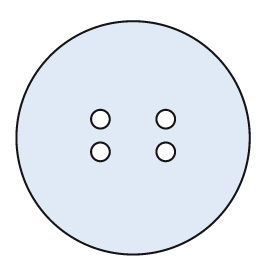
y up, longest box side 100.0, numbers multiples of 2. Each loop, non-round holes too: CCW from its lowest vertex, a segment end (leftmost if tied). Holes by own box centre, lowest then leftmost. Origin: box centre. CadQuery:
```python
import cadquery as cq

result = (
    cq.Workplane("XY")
    .moveTo(0.0, 0.0)
    .circle(50.0)
    .moveTo(-14.0, -6.0)
    .circle(4.0)
    .moveTo(14.0, -6.0)
    .circle(4.0)
    .moveTo(-14.0, 8.0)
    .circle(4.0)
    .moveTo(14.0, 8.0)
    .circle(4.0)
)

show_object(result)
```